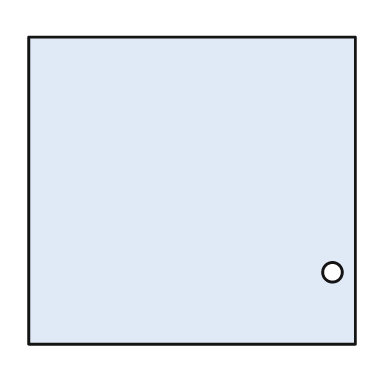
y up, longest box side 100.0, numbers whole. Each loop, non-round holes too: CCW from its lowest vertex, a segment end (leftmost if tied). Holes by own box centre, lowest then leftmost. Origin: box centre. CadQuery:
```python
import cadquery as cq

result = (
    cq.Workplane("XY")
    .moveTo(-50.0, -47.0)
    .lineTo(50.0, -47.0)
    .lineTo(50.0, 47.0)
    .lineTo(-50.0, 47.0)
    .close()
    .moveTo(43.0, -25.0)
    .circle(3.0)
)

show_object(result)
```